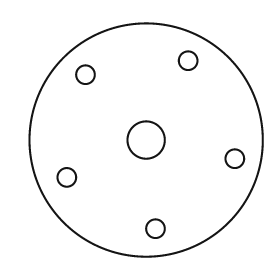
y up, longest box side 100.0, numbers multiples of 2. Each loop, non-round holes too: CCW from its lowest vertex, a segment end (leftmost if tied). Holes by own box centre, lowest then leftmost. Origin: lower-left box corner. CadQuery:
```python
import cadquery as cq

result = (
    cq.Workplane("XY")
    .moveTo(50.0, 50.0)
    .circle(50.0)
    .moveTo(54.0, 12.0)
    .circle(4.0)
    .moveTo(16.0, 34.0)
    .circle(4.0)
    .moveTo(88.0, 42.0)
    .circle(4.0)
    .moveTo(50.0, 50.0)
    .circle(8.0)
    .moveTo(24.0, 78.0)
    .circle(4.0)
    .moveTo(68.0, 84.0)
    .circle(4.0)
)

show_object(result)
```